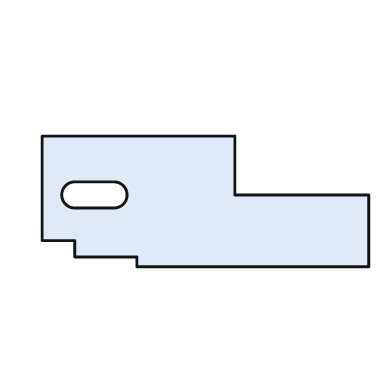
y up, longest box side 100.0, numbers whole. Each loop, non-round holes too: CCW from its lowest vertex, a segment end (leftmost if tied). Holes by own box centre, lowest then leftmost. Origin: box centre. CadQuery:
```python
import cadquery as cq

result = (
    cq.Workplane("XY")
    .moveTo(-21.0, -20.0)
    .lineTo(50.0, -20.0)
    .lineTo(50.0, 2.0)
    .lineTo(9.0, 2.0)
    .lineTo(9.0, 20.0)
    .lineTo(-50.0, 20.0)
    .lineTo(-50.0, -12.0)
    .lineTo(-40.0, -12.0)
    .lineTo(-40.0, -17.0)
    .lineTo(-21.0, -17.0)
    .close()
    .moveTo(-40.0, -2.0)
    .lineTo(-28.0, -2.0)
    .threePointArc((-24.0, 2.0), (-28.0, 6.0))
    .lineTo(-40.0, 6.0)
    .threePointArc((-44.0, 2.0), (-40.0, -2.0))
    .close()
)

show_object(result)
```